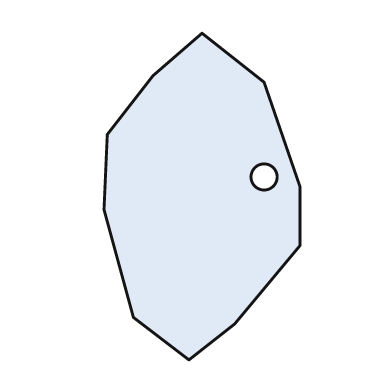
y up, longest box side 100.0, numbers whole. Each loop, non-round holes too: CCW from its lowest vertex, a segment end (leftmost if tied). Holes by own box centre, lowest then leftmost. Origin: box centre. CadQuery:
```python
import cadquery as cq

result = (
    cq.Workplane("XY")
    .moveTo(-4.0, -50.0)
    .lineTo(10.0, -39.0)
    .lineTo(30.0, -15.0)
    .lineTo(30.0, 3.0)
    .lineTo(19.0, 35.0)
    .lineTo(0.0, 50.0)
    .lineTo(-15.0, 37.0)
    .lineTo(-29.0, 19.0)
    .lineTo(-30.0, -4.0)
    .lineTo(-21.0, -37.0)
    .close()
    .moveTo(19.0, 6.0)
    .circle(4.0)
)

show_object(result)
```